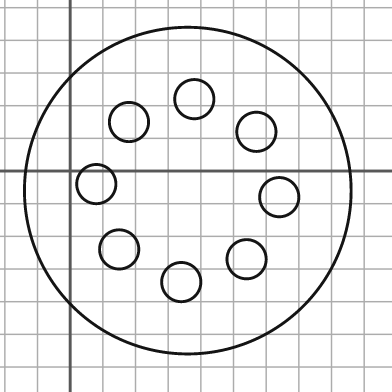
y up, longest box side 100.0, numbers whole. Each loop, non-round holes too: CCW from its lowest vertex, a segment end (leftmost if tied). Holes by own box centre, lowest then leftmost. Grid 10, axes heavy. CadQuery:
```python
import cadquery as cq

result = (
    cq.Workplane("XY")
    .moveTo(36.0, -6.0)
    .circle(50.0)
    .moveTo(34.0, -34.0)
    .circle(6.0)
    .moveTo(54.0, -27.0)
    .circle(6.0)
    .moveTo(15.0, -24.0)
    .circle(6.0)
    .moveTo(64.0, -8.0)
    .circle(6.0)
    .moveTo(8.0, -4.0)
    .circle(6.0)
    .moveTo(57.0, 12.0)
    .circle(6.0)
    .moveTo(18.0, 15.0)
    .circle(6.0)
    .moveTo(38.0, 22.0)
    .circle(6.0)
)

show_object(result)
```